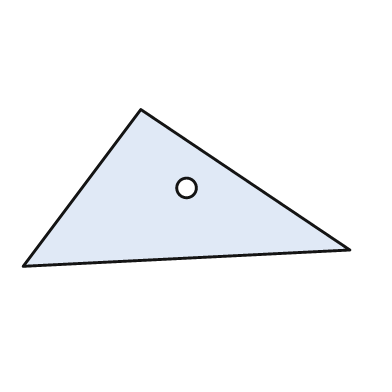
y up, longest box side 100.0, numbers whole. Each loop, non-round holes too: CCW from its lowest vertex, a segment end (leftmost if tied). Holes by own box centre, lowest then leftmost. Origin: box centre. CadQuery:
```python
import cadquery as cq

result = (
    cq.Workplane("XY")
    .moveTo(-50.0, -24.0)
    .lineTo(50.0, -19.0)
    .lineTo(-14.0, 24.0)
    .close()
    .moveTo(0.0, 0.0)
    .circle(3.0)
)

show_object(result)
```